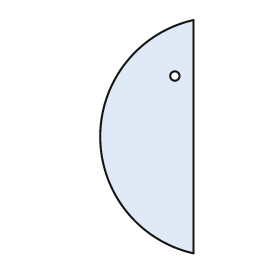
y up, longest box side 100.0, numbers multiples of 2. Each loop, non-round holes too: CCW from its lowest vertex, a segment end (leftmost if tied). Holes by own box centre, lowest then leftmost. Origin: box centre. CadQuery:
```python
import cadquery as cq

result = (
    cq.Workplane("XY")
    .moveTo(20.0, -50.0)
    .lineTo(20.0, 50.0)
    .threePointArc((-20.0, 0.0), (20.0, -50.0))
    .close()
    .moveTo(12.0, 26.0)
    .circle(2.0)
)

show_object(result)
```